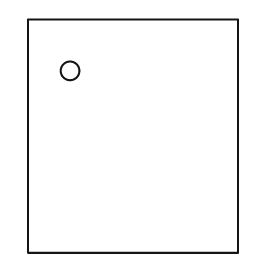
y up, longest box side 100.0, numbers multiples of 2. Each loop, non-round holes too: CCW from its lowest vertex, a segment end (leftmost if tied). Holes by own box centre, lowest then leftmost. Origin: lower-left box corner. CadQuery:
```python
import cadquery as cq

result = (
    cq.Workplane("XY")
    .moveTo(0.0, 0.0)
    .lineTo(90.0, 0.0)
    .lineTo(90.0, 100.0)
    .lineTo(0.0, 100.0)
    .close()
    .moveTo(18.0, 78.0)
    .circle(4.0)
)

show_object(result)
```